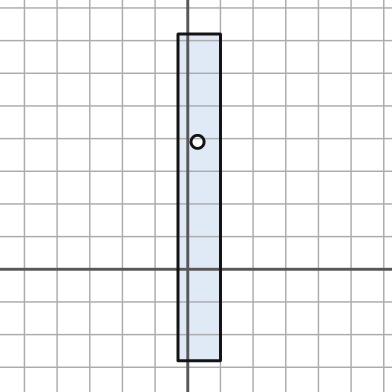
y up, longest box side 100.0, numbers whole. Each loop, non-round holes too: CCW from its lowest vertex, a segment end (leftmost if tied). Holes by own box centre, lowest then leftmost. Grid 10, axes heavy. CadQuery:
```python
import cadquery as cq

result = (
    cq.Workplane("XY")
    .moveTo(-3.0, -28.0)
    .lineTo(10.0, -28.0)
    .lineTo(10.0, 72.0)
    .lineTo(-3.0, 72.0)
    .close()
    .moveTo(3.0, 39.0)
    .circle(2.0)
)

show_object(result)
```